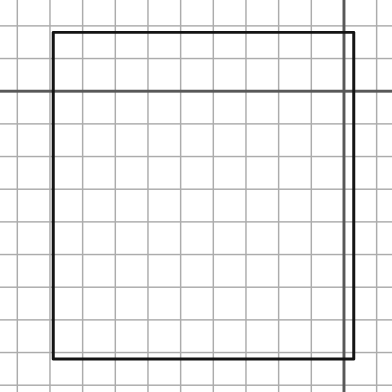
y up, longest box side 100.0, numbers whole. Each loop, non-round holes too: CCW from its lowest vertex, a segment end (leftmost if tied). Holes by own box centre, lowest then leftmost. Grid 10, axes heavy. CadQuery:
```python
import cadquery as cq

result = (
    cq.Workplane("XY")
    .moveTo(-89.0, -82.0)
    .lineTo(3.0, -82.0)
    .lineTo(3.0, 18.0)
    .lineTo(-89.0, 18.0)
    .close()
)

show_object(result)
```